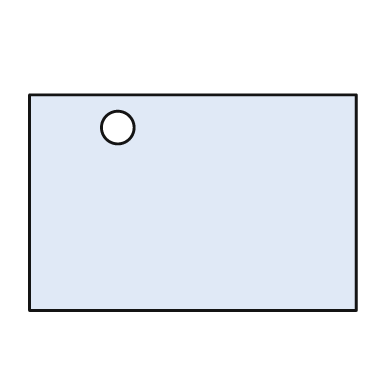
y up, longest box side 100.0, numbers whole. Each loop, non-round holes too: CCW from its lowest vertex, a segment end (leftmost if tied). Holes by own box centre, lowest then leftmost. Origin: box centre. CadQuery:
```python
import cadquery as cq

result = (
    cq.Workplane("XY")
    .moveTo(-50.0, -33.0)
    .lineTo(50.0, -33.0)
    .lineTo(50.0, 33.0)
    .lineTo(-50.0, 33.0)
    .close()
    .moveTo(-23.0, 23.0)
    .circle(5.0)
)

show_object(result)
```